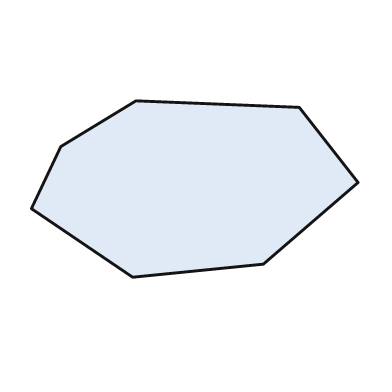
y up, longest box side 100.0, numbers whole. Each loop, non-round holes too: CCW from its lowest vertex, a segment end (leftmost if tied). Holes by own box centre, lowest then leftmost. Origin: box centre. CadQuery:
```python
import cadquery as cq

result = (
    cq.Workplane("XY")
    .moveTo(-19.0, -27.0)
    .lineTo(21.0, -23.0)
    .lineTo(50.0, 2.0)
    .lineTo(32.0, 25.0)
    .lineTo(-18.0, 27.0)
    .lineTo(-41.0, 13.0)
    .lineTo(-50.0, -6.0)
    .close()
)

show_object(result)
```